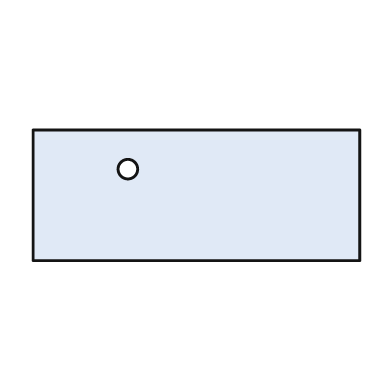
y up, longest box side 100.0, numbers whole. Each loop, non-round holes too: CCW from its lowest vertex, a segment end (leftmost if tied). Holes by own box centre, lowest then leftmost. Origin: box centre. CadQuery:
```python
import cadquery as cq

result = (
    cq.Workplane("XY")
    .moveTo(-50.0, -20.0)
    .lineTo(50.0, -20.0)
    .lineTo(50.0, 20.0)
    .lineTo(-50.0, 20.0)
    .close()
    .moveTo(-21.0, 8.0)
    .circle(3.0)
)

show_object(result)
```